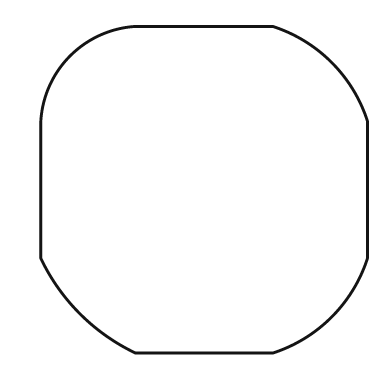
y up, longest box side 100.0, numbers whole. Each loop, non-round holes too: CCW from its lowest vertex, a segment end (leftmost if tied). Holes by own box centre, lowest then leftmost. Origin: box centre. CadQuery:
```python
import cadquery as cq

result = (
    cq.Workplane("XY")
    .moveTo(-21.0, -50.0)
    .lineTo(21.0, -50.0)
    .threePointArc((39.0, -39.0), (50.0, -21.0))
    .lineTo(50.0, 21.0)
    .threePointArc((39.0, 39.0), (21.0, 50.0))
    .lineTo(-21.0, 50.0)
    .threePointArc((-41.0, 41.0), (-50.0, 21.0))
    .lineTo(-50.0, -21.0)
    .threePointArc((-38.0, -38.0), (-21.0, -50.0))
    .close()
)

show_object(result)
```